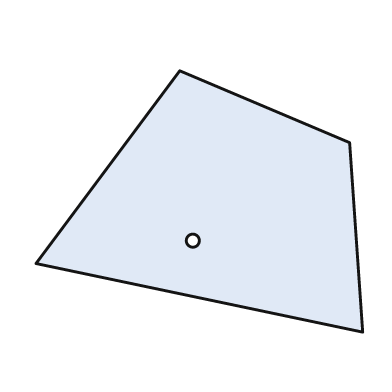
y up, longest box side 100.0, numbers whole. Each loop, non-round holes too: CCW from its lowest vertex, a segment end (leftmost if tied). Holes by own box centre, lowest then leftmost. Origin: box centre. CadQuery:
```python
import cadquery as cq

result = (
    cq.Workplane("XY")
    .moveTo(50.0, -40.0)
    .lineTo(46.0, 18.0)
    .lineTo(-6.0, 40.0)
    .lineTo(-50.0, -19.0)
    .close()
    .moveTo(-2.0, -12.0)
    .circle(2.0)
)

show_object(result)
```